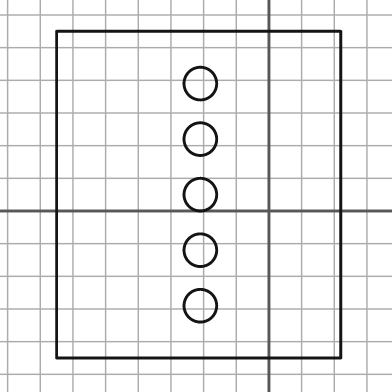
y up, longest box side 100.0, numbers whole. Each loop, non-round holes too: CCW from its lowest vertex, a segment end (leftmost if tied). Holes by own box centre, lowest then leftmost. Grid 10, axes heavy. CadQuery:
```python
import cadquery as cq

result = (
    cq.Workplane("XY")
    .moveTo(-65.0, -45.0)
    .lineTo(22.0, -45.0)
    .lineTo(22.0, 55.0)
    .lineTo(-65.0, 55.0)
    .close()
    .moveTo(-21.0, -29.0)
    .circle(5.0)
    .moveTo(-21.0, -12.0)
    .circle(5.0)
    .moveTo(-21.0, 5.0)
    .circle(5.0)
    .moveTo(-21.0, 22.0)
    .circle(5.0)
    .moveTo(-21.0, 39.0)
    .circle(5.0)
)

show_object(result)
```